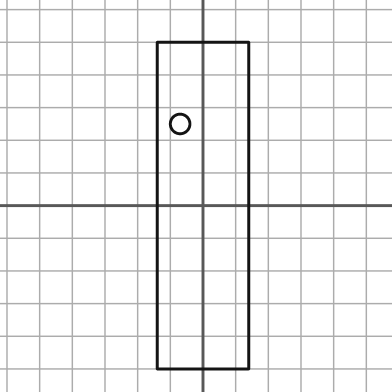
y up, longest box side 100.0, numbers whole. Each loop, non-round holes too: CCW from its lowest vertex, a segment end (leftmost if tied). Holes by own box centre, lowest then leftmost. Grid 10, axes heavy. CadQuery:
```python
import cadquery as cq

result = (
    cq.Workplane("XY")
    .moveTo(-14.0, -50.0)
    .lineTo(14.0, -50.0)
    .lineTo(14.0, 50.0)
    .lineTo(-14.0, 50.0)
    .close()
    .moveTo(-7.0, 25.0)
    .circle(3.0)
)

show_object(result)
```